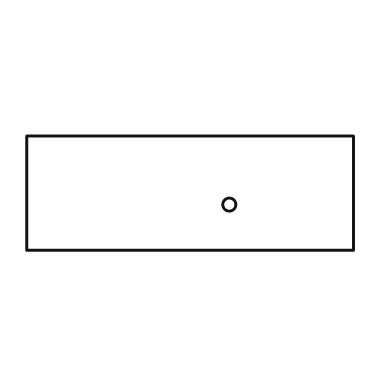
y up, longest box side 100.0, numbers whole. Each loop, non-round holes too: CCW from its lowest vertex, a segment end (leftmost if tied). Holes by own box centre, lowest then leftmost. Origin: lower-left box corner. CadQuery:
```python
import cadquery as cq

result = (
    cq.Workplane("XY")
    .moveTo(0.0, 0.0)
    .lineTo(100.0, 0.0)
    .lineTo(100.0, 35.0)
    .lineTo(0.0, 35.0)
    .close()
    .moveTo(62.0, 14.0)
    .circle(2.0)
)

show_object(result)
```